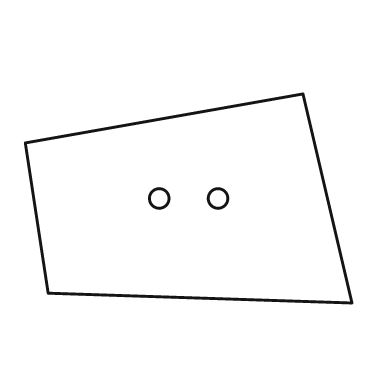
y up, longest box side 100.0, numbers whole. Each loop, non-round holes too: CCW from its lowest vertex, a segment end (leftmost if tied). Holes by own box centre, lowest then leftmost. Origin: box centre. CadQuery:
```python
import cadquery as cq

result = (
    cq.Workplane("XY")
    .moveTo(50.0, -32.0)
    .lineTo(35.0, 32.0)
    .lineTo(-50.0, 17.0)
    .lineTo(-43.0, -29.0)
    .close()
    .moveTo(-9.0, 0.0)
    .circle(3.0)
    .moveTo(9.0, 0.0)
    .circle(3.0)
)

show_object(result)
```